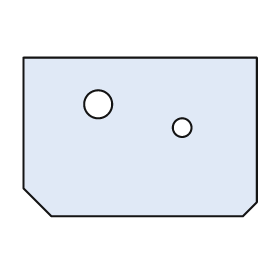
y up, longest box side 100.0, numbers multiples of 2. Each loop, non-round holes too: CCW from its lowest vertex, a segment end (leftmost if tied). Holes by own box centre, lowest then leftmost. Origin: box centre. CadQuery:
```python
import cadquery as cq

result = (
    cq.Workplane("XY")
    .moveTo(-38.0, -34.0)
    .lineTo(44.0, -34.0)
    .lineTo(50.0, -28.0)
    .lineTo(50.0, 34.0)
    .lineTo(-50.0, 34.0)
    .lineTo(-50.0, -22.0)
    .close()
    .moveTo(18.0, 4.0)
    .circle(4.0)
    .moveTo(-18.0, 14.0)
    .circle(6.0)
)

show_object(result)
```